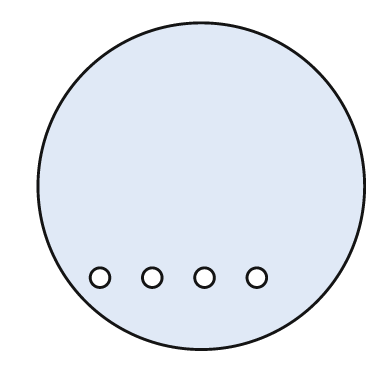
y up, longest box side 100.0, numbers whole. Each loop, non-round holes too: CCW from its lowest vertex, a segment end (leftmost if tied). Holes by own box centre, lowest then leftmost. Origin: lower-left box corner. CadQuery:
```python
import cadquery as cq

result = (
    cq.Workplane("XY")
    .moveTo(50.0, 50.0)
    .circle(50.0)
    .moveTo(19.0, 22.0)
    .circle(3.0)
    .moveTo(35.0, 22.0)
    .circle(3.0)
    .moveTo(51.0, 22.0)
    .circle(3.0)
    .moveTo(67.0, 22.0)
    .circle(3.0)
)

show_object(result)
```